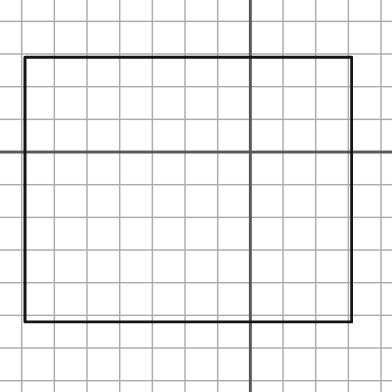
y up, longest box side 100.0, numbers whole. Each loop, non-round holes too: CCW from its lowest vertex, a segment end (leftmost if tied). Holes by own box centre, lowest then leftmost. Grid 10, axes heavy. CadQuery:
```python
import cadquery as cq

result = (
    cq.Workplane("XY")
    .moveTo(-69.0, -52.0)
    .lineTo(31.0, -52.0)
    .lineTo(31.0, 29.0)
    .lineTo(-69.0, 29.0)
    .close()
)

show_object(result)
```